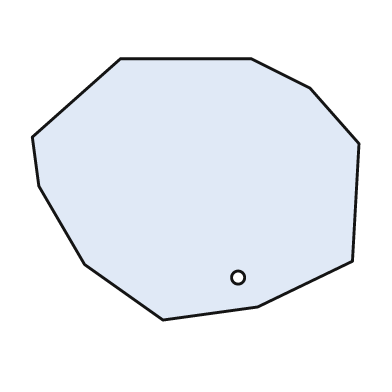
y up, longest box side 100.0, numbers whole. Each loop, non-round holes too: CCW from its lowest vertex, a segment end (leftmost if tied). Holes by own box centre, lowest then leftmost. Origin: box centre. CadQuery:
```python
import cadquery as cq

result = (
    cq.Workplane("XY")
    .moveTo(-10.0, -40.0)
    .lineTo(19.0, -36.0)
    .lineTo(48.0, -22.0)
    .lineTo(50.0, 14.0)
    .lineTo(35.0, 31.0)
    .lineTo(17.0, 40.0)
    .lineTo(-23.0, 40.0)
    .lineTo(-50.0, 16.0)
    .lineTo(-48.0, 1.0)
    .lineTo(-34.0, -23.0)
    .close()
    .moveTo(13.0, -27.0)
    .circle(2.0)
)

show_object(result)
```